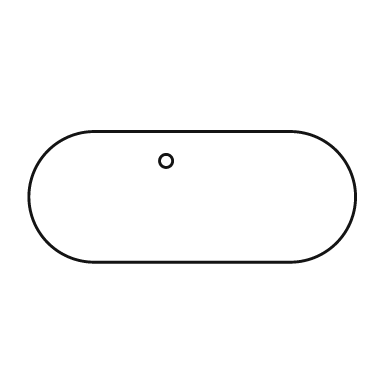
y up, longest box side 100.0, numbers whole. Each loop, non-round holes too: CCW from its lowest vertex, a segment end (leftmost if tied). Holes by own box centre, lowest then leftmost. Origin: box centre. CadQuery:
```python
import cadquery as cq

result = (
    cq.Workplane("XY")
    .moveTo(-30.0, -20.0)
    .lineTo(30.0, -20.0)
    .threePointArc((50.0, 0.0), (30.0, 20.0))
    .lineTo(-30.0, 20.0)
    .threePointArc((-50.0, 0.0), (-30.0, -20.0))
    .close()
    .moveTo(-8.0, 11.0)
    .circle(2.0)
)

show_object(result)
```